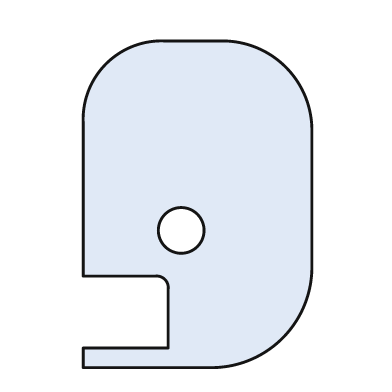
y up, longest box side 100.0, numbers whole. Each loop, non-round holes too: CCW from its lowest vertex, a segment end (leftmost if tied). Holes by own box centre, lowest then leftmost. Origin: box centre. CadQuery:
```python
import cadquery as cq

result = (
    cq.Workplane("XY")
    .moveTo(-35.0, -50.0)
    .lineTo(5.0, -50.0)
    .threePointArc((26.0, -41.0), (35.0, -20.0))
    .lineTo(35.0, 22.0)
    .threePointArc((27.0, 42.0), (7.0, 50.0))
    .lineTo(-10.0, 50.0)
    .threePointArc((-28.0, 43.0), (-35.0, 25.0))
    .lineTo(-35.0, -22.0)
    .lineTo(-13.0, -22.0)
    .threePointArc((-10.0, -23.0), (-9.0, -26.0))
    .lineTo(-9.0, -44.0)
    .lineTo(-35.0, -44.0)
    .close()
    .moveTo(-5.0, -8.0)
    .circle(7.0)
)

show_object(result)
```